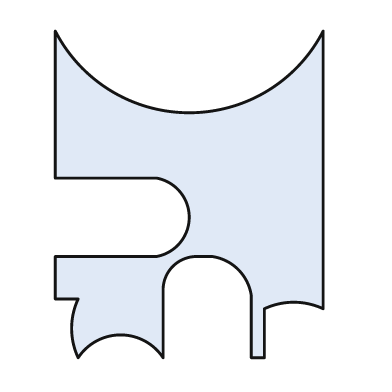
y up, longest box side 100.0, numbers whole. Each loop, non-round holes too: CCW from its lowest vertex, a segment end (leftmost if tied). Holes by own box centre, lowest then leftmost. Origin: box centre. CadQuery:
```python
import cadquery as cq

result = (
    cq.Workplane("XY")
    .moveTo(-34.0, -50.0)
    .threePointArc((-21.0, -43.0), (-8.0, -50.0))
    .lineTo(-8.0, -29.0)
    .threePointArc((-5.0, -22.0), (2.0, -19.0))
    .lineTo(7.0, -19.0)
    .threePointArc((15.0, -23.0), (19.0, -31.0))
    .lineTo(19.0, -50.0)
    .lineTo(23.0, -50.0)
    .lineTo(23.0, -35.0)
    .threePointArc((32.0, -33.0), (41.0, -35.0))
    .lineTo(41.0, 50.0)
    .threePointArc((0.0, 25.0), (-41.0, 50.0))
    .lineTo(-41.0, 5.0)
    .lineTo(-10.0, 5.0)
    .threePointArc((0.0, -7.0), (-10.0, -19.0))
    .lineTo(-41.0, -19.0)
    .lineTo(-41.0, -32.0)
    .lineTo(-34.0, -32.0)
    .threePointArc((-36.0, -41.0), (-34.0, -50.0))
    .close()
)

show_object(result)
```